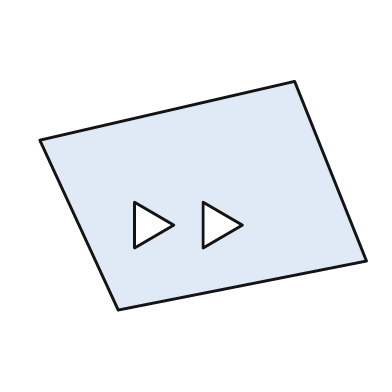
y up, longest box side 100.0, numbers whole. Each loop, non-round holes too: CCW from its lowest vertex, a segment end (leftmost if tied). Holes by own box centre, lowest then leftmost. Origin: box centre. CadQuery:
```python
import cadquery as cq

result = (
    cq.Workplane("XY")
    .moveTo(-26.0, -35.0)
    .lineTo(50.0, -20.0)
    .lineTo(28.0, 35.0)
    .lineTo(-50.0, 17.0)
    .close()
    .moveTo(-21.0, -16.0)
    .lineTo(-9.0, -9.0)
    .lineTo(-21.0, -2.0)
    .close()
    .moveTo(0.0, -16.0)
    .lineTo(12.0, -9.0)
    .lineTo(0.0, -2.0)
    .close()
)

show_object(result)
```